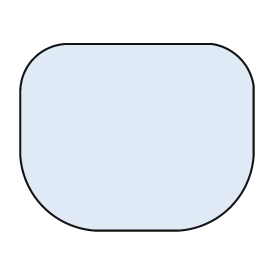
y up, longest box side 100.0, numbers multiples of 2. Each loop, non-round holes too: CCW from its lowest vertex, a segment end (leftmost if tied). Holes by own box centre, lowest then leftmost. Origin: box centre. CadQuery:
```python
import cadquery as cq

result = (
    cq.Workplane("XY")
    .moveTo(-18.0, -40.0)
    .lineTo(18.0, -40.0)
    .threePointArc((40.0, -30.0), (50.0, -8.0))
    .lineTo(50.0, 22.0)
    .threePointArc((44.0, 34.0), (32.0, 40.0))
    .lineTo(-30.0, 40.0)
    .threePointArc((-44.0, 34.0), (-50.0, 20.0))
    .lineTo(-50.0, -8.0)
    .threePointArc((-40.0, -30.0), (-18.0, -40.0))
    .close()
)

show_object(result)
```